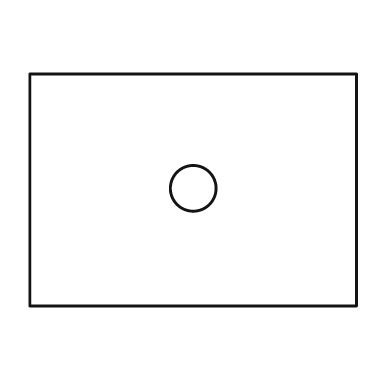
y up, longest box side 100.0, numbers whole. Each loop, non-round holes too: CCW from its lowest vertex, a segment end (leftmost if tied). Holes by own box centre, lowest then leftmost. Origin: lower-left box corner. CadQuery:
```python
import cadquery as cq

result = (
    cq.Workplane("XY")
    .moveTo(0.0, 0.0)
    .lineTo(100.0, 0.0)
    .lineTo(100.0, 71.0)
    .lineTo(0.0, 71.0)
    .close()
    .moveTo(50.0, 36.0)
    .circle(7.0)
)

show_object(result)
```